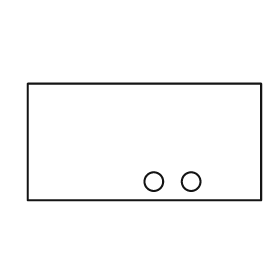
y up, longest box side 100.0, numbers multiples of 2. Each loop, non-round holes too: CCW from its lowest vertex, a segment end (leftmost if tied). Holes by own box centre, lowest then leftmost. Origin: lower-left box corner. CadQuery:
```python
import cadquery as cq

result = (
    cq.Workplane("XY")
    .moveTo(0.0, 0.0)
    .lineTo(100.0, 0.0)
    .lineTo(100.0, 50.0)
    .lineTo(0.0, 50.0)
    .close()
    .moveTo(54.0, 8.0)
    .circle(4.0)
    .moveTo(70.0, 8.0)
    .circle(4.0)
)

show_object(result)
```